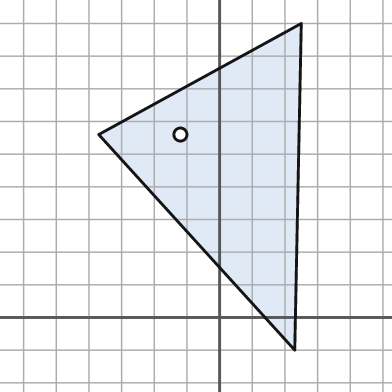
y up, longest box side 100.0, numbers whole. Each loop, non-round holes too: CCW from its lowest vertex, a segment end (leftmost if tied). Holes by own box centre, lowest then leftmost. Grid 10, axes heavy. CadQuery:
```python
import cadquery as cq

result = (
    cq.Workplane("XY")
    .moveTo(23.0, -10.0)
    .lineTo(25.0, 90.0)
    .lineTo(-37.0, 56.0)
    .close()
    .moveTo(-12.0, 56.0)
    .circle(2.0)
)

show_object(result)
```